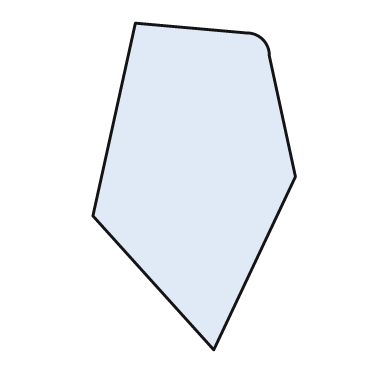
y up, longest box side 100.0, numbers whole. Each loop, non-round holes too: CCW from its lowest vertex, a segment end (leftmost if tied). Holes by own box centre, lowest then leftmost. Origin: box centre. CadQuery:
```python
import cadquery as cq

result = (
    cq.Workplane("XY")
    .moveTo(6.0, -50.0)
    .lineTo(31.0, 3.0)
    .lineTo(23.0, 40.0)
    .threePointArc((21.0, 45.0), (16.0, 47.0))
    .lineTo(-18.0, 50.0)
    .lineTo(-31.0, -9.0)
    .close()
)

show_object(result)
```